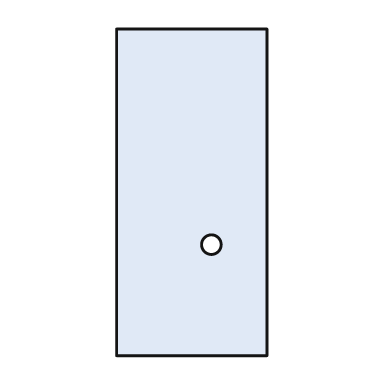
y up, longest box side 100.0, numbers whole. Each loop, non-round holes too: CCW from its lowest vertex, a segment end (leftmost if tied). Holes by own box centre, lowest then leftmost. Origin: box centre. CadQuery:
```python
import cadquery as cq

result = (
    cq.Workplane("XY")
    .moveTo(-23.0, -50.0)
    .lineTo(23.0, -50.0)
    .lineTo(23.0, 50.0)
    .lineTo(-23.0, 50.0)
    .close()
    .moveTo(6.0, -16.0)
    .circle(3.0)
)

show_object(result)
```